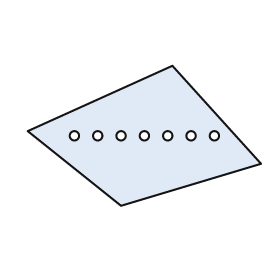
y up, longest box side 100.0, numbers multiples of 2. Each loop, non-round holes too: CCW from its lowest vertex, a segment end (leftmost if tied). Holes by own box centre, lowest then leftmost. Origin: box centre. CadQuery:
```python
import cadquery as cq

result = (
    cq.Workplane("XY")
    .moveTo(-10.0, -30.0)
    .lineTo(50.0, -12.0)
    .lineTo(12.0, 30.0)
    .lineTo(-50.0, 2.0)
    .close()
    .moveTo(-30.0, 0.0)
    .circle(2.0)
    .moveTo(-20.0, 0.0)
    .circle(2.0)
    .moveTo(-10.0, 0.0)
    .circle(2.0)
    .moveTo(0.0, 0.0)
    .circle(2.0)
    .moveTo(10.0, 0.0)
    .circle(2.0)
    .moveTo(20.0, 0.0)
    .circle(2.0)
    .moveTo(30.0, 0.0)
    .circle(2.0)
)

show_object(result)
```